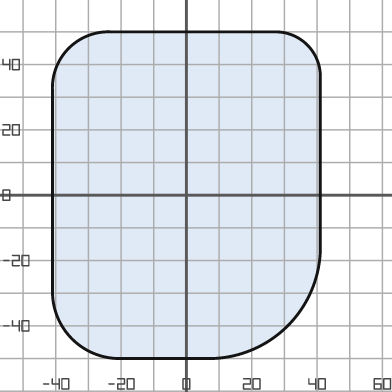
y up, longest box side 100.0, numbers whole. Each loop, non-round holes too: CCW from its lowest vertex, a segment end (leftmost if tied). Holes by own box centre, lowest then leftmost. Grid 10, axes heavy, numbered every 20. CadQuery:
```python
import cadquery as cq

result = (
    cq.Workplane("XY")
    .moveTo(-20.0, -50.0)
    .lineTo(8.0, -50.0)
    .threePointArc((31.0, -40.0), (41.0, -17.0))
    .lineTo(41.0, 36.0)
    .threePointArc((37.0, 46.0), (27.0, 50.0))
    .lineTo(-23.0, 50.0)
    .threePointArc((-36.0, 45.0), (-41.0, 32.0))
    .lineTo(-41.0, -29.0)
    .threePointArc((-35.0, -44.0), (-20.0, -50.0))
    .close()
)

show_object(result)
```